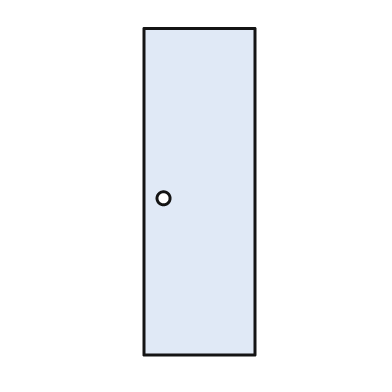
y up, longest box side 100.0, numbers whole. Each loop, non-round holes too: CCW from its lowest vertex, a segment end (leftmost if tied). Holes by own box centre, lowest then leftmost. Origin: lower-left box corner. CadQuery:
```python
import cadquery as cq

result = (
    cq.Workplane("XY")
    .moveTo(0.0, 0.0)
    .lineTo(34.0, 0.0)
    .lineTo(34.0, 100.0)
    .lineTo(0.0, 100.0)
    .close()
    .moveTo(6.0, 48.0)
    .circle(2.0)
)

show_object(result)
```